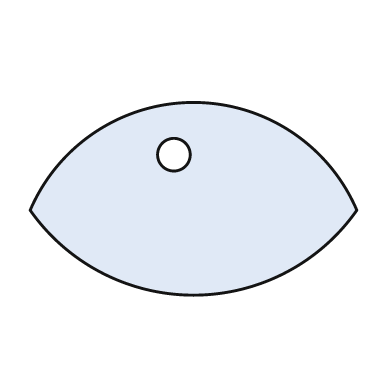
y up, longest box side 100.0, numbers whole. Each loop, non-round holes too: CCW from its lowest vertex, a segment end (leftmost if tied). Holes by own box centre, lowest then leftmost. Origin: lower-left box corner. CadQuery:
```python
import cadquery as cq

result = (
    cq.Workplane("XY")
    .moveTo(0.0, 26.0)
    .threePointArc((50.0, 0.0), (100.0, 26.0))
    .threePointArc((50.0, 59.0), (0.0, 26.0))
    .close()
    .moveTo(44.0, 43.0)
    .circle(5.0)
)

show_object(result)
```